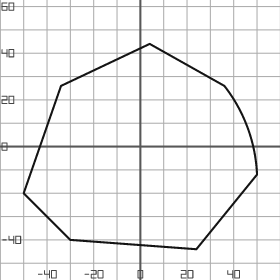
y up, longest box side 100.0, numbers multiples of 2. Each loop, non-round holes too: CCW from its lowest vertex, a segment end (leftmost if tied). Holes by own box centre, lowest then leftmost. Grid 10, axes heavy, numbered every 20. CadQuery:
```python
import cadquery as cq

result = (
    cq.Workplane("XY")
    .moveTo(24.0, -44.0)
    .lineTo(50.0, -12.0)
    .threePointArc((46.0, 8.0), (36.0, 26.0))
    .lineTo(4.0, 44.0)
    .lineTo(-34.0, 26.0)
    .lineTo(-50.0, -20.0)
    .lineTo(-30.0, -40.0)
    .close()
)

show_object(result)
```